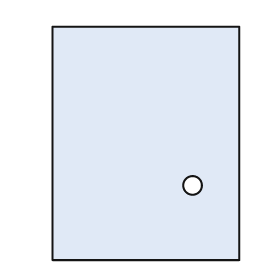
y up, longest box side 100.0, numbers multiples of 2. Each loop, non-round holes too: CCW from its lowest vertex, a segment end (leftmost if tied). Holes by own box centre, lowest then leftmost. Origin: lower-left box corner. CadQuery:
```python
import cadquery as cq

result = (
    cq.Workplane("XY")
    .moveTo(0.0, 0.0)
    .lineTo(80.0, 0.0)
    .lineTo(80.0, 100.0)
    .lineTo(0.0, 100.0)
    .close()
    .moveTo(60.0, 32.0)
    .circle(4.0)
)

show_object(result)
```